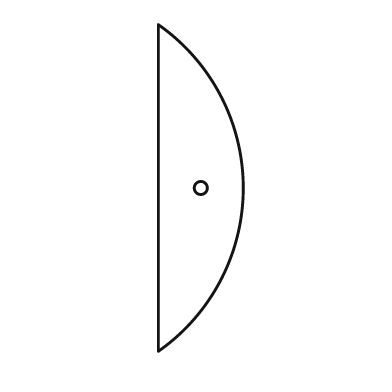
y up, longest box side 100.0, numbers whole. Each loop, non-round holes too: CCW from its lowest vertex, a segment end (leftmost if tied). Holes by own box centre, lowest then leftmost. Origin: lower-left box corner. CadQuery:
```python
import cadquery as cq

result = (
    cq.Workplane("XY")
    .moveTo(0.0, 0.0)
    .threePointArc((26.0, 50.0), (0.0, 100.0))
    .close()
    .moveTo(13.0, 50.0)
    .circle(2.0)
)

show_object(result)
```